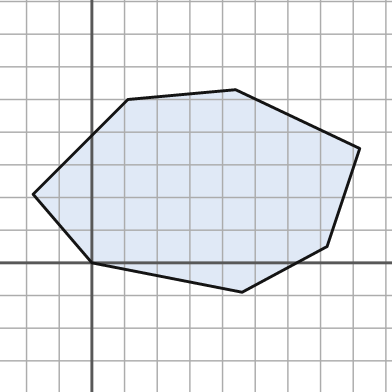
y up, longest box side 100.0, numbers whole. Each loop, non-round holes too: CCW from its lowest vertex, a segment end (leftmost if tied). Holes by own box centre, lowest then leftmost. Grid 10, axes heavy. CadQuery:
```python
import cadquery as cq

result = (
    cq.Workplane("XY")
    .moveTo(46.0, -9.0)
    .lineTo(72.0, 5.0)
    .lineTo(82.0, 35.0)
    .lineTo(44.0, 53.0)
    .lineTo(11.0, 50.0)
    .lineTo(-18.0, 21.0)
    .lineTo(0.0, 0.0)
    .close()
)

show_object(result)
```